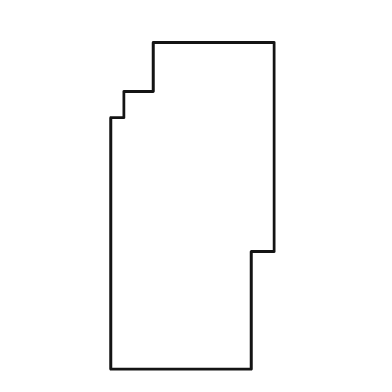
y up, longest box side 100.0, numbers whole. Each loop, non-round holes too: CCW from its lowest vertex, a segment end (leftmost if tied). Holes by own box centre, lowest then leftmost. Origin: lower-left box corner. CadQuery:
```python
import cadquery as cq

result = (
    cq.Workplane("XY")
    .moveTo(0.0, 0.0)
    .lineTo(43.0, 0.0)
    .lineTo(43.0, 36.0)
    .lineTo(50.0, 36.0)
    .lineTo(50.0, 100.0)
    .lineTo(13.0, 100.0)
    .lineTo(13.0, 85.0)
    .lineTo(4.0, 85.0)
    .lineTo(4.0, 77.0)
    .lineTo(0.0, 77.0)
    .close()
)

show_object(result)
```